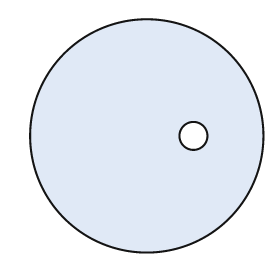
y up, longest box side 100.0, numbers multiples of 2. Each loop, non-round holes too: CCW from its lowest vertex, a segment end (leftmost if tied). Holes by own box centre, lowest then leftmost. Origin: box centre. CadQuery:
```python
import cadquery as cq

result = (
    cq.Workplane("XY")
    .moveTo(0.0, 0.0)
    .circle(50.0)
    .moveTo(20.0, 0.0)
    .circle(6.0)
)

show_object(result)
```